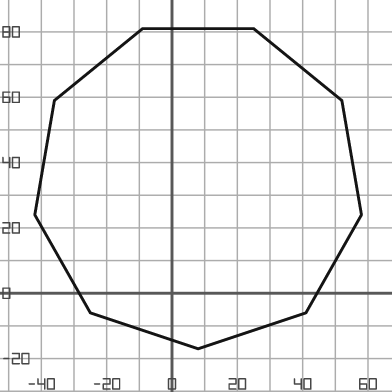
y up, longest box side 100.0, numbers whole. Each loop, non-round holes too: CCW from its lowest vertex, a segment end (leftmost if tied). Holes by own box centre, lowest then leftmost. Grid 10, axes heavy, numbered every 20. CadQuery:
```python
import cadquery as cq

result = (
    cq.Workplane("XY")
    .moveTo(8.0, -17.0)
    .lineTo(41.0, -6.0)
    .lineTo(58.0, 24.0)
    .lineTo(52.0, 59.0)
    .lineTo(25.0, 81.0)
    .lineTo(-9.0, 81.0)
    .lineTo(-36.0, 59.0)
    .lineTo(-42.0, 24.0)
    .lineTo(-25.0, -6.0)
    .close()
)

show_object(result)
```